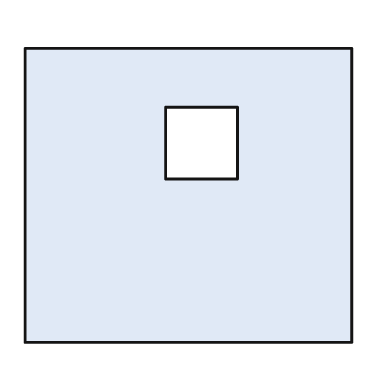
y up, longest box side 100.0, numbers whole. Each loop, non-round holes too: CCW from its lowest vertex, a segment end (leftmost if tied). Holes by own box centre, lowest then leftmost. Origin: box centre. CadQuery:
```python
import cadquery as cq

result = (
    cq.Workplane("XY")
    .moveTo(-50.0, -45.0)
    .lineTo(50.0, -45.0)
    .lineTo(50.0, 45.0)
    .lineTo(-50.0, 45.0)
    .close()
    .moveTo(-7.0, 5.0)
    .lineTo(15.0, 5.0)
    .lineTo(15.0, 27.0)
    .lineTo(-7.0, 27.0)
    .close()
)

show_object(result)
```